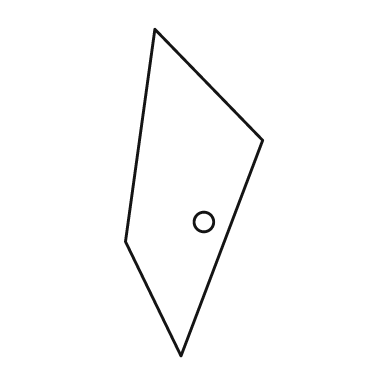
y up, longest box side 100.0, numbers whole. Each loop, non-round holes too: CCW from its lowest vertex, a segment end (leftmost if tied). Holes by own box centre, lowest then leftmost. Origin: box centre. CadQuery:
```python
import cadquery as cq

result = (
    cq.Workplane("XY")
    .moveTo(-4.0, -50.0)
    .lineTo(21.0, 16.0)
    .lineTo(-12.0, 50.0)
    .lineTo(-21.0, -15.0)
    .close()
    .moveTo(3.0, -9.0)
    .circle(3.0)
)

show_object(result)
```